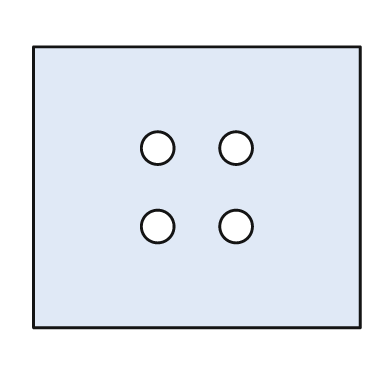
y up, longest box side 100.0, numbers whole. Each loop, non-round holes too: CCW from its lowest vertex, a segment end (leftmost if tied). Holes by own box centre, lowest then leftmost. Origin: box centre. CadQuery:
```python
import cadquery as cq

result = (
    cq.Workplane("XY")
    .moveTo(-50.0, -43.0)
    .lineTo(50.0, -43.0)
    .lineTo(50.0, 43.0)
    .lineTo(-50.0, 43.0)
    .close()
    .moveTo(-12.0, -12.0)
    .circle(5.0)
    .moveTo(12.0, -12.0)
    .circle(5.0)
    .moveTo(-12.0, 12.0)
    .circle(5.0)
    .moveTo(12.0, 12.0)
    .circle(5.0)
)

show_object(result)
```